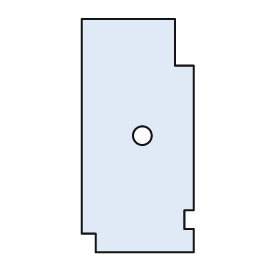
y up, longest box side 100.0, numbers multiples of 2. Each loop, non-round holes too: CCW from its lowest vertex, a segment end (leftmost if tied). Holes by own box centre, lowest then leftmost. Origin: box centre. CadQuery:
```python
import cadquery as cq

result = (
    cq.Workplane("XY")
    .moveTo(-18.0, -50.0)
    .lineTo(24.0, -50.0)
    .lineTo(24.0, -40.0)
    .lineTo(20.0, -40.0)
    .lineTo(20.0, -32.0)
    .lineTo(24.0, -32.0)
    .lineTo(24.0, 30.0)
    .lineTo(16.0, 30.0)
    .lineTo(16.0, 50.0)
    .lineTo(-24.0, 50.0)
    .lineTo(-24.0, -42.0)
    .lineTo(-18.0, -42.0)
    .close()
    .moveTo(2.0, 0.0)
    .circle(4.0)
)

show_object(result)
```